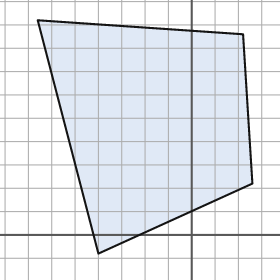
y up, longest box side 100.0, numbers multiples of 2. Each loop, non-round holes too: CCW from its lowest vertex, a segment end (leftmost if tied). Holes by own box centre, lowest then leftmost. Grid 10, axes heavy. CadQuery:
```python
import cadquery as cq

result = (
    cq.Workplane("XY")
    .moveTo(-40.0, -8.0)
    .lineTo(26.0, 22.0)
    .lineTo(22.0, 86.0)
    .lineTo(-66.0, 92.0)
    .close()
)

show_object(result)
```